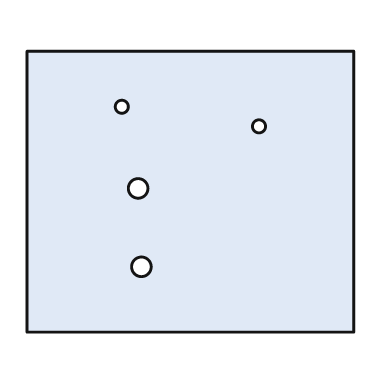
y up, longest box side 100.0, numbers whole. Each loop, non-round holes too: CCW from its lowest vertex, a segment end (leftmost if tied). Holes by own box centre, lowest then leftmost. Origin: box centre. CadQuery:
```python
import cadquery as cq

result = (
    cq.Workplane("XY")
    .moveTo(-50.0, -43.0)
    .lineTo(50.0, -43.0)
    .lineTo(50.0, 43.0)
    .lineTo(-50.0, 43.0)
    .close()
    .moveTo(-15.0, -23.0)
    .circle(3.0)
    .moveTo(-16.0, 1.0)
    .circle(3.0)
    .moveTo(21.0, 20.0)
    .circle(2.0)
    .moveTo(-21.0, 26.0)
    .circle(2.0)
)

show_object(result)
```